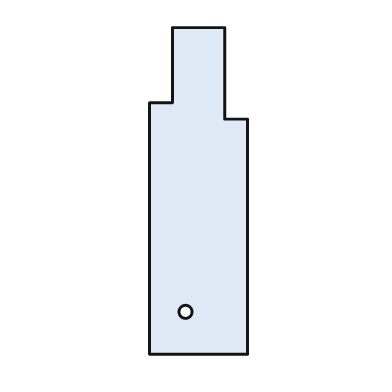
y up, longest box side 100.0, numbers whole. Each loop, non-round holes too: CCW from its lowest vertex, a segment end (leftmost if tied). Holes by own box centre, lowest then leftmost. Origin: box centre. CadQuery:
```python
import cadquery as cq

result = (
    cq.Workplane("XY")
    .moveTo(-15.0, -50.0)
    .lineTo(15.0, -50.0)
    .lineTo(15.0, 22.0)
    .lineTo(8.0, 22.0)
    .lineTo(8.0, 50.0)
    .lineTo(-8.0, 50.0)
    .lineTo(-8.0, 27.0)
    .lineTo(-15.0, 27.0)
    .close()
    .moveTo(-4.0, -37.0)
    .circle(2.0)
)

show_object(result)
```